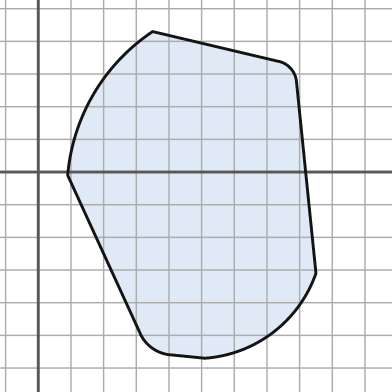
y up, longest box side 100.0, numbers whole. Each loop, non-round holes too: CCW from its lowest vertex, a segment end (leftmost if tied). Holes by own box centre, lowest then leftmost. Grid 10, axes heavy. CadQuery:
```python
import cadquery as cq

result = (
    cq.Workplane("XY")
    .moveTo(51.0, -57.0)
    .threePointArc((72.0, -49.0), (85.0, -31.0))
    .lineTo(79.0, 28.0)
    .threePointArc((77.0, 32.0), (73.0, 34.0))
    .lineTo(35.0, 43.0)
    .threePointArc((17.0, 24.0), (9.0, -1.0))
    .lineTo(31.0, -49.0)
    .threePointArc((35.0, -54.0), (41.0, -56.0))
    .close()
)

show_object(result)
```